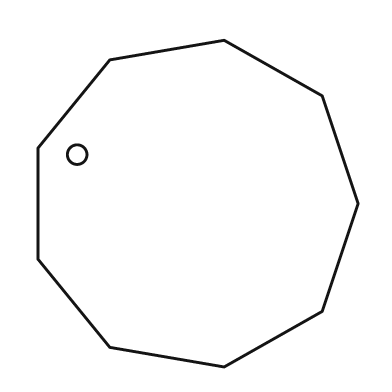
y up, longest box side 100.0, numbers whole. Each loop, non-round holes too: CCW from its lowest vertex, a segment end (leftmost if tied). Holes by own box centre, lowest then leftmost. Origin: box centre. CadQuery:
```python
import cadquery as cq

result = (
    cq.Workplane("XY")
    .moveTo(8.0, -50.0)
    .lineTo(38.0, -33.0)
    .lineTo(49.0, 0.0)
    .lineTo(38.0, 33.0)
    .lineTo(8.0, 50.0)
    .lineTo(-27.0, 44.0)
    .lineTo(-49.0, 17.0)
    .lineTo(-49.0, -17.0)
    .lineTo(-27.0, -44.0)
    .close()
    .moveTo(-37.0, 15.0)
    .circle(3.0)
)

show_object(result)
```